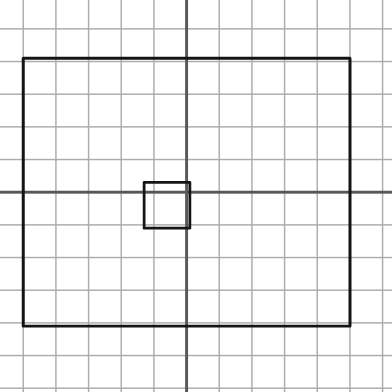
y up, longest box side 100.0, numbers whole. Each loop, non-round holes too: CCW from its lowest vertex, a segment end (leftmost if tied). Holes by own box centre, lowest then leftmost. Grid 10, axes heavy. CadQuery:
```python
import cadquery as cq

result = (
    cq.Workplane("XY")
    .moveTo(-50.0, -41.0)
    .lineTo(50.0, -41.0)
    .lineTo(50.0, 41.0)
    .lineTo(-50.0, 41.0)
    .close()
    .moveTo(-13.0, -11.0)
    .lineTo(1.0, -11.0)
    .lineTo(1.0, 3.0)
    .lineTo(-13.0, 3.0)
    .close()
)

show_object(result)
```